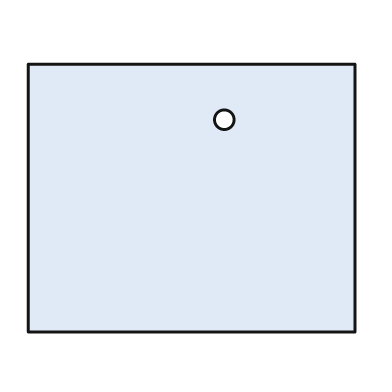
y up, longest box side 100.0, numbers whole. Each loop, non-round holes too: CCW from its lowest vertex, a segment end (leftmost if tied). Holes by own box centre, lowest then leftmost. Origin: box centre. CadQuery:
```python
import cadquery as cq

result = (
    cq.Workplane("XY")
    .moveTo(-50.0, -41.0)
    .lineTo(50.0, -41.0)
    .lineTo(50.0, 41.0)
    .lineTo(-50.0, 41.0)
    .close()
    .moveTo(10.0, 24.0)
    .circle(3.0)
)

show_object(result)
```